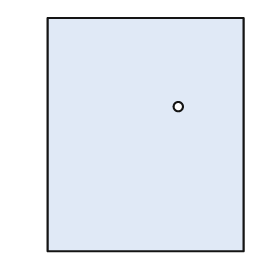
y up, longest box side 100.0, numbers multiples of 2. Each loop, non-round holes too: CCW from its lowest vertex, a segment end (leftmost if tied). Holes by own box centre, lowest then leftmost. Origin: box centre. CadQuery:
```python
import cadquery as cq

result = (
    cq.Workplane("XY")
    .moveTo(-42.0, -50.0)
    .lineTo(42.0, -50.0)
    .lineTo(42.0, 50.0)
    .lineTo(-42.0, 50.0)
    .close()
    .moveTo(14.0, 12.0)
    .circle(2.0)
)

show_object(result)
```